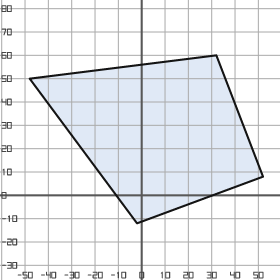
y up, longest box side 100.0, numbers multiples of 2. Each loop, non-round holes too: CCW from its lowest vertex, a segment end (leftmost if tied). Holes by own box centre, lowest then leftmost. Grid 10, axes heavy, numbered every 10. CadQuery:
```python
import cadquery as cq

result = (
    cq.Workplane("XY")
    .moveTo(-2.0, -12.0)
    .lineTo(52.0, 8.0)
    .lineTo(32.0, 60.0)
    .lineTo(-48.0, 50.0)
    .close()
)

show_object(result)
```